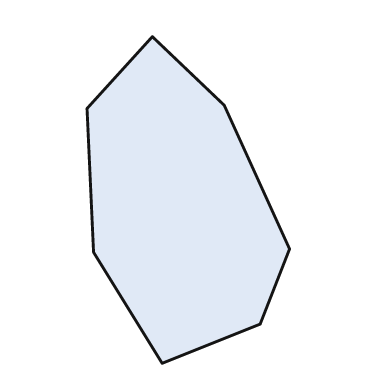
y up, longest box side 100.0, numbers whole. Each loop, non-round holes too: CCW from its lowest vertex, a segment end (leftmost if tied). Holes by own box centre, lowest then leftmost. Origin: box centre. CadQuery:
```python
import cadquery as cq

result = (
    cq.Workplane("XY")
    .moveTo(-8.0, -50.0)
    .lineTo(22.0, -38.0)
    .lineTo(31.0, -15.0)
    .lineTo(11.0, 29.0)
    .lineTo(-11.0, 50.0)
    .lineTo(-31.0, 28.0)
    .lineTo(-29.0, -16.0)
    .close()
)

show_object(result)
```